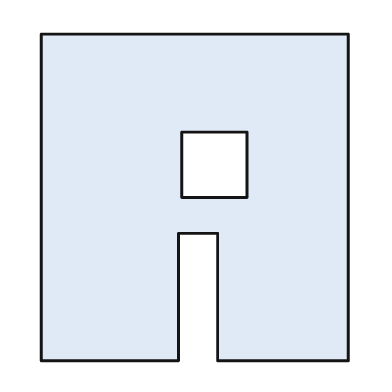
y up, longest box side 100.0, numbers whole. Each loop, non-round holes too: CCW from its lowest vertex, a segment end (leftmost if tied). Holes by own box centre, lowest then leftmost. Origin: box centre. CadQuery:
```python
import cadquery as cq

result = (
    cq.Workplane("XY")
    .moveTo(-47.0, -50.0)
    .lineTo(-5.0, -50.0)
    .lineTo(-5.0, -11.0)
    .lineTo(7.0, -11.0)
    .lineTo(7.0, -50.0)
    .lineTo(47.0, -50.0)
    .lineTo(47.0, 50.0)
    .lineTo(-47.0, 50.0)
    .close()
    .moveTo(-4.0, 0.0)
    .lineTo(16.0, 0.0)
    .lineTo(16.0, 20.0)
    .lineTo(-4.0, 20.0)
    .close()
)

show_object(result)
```